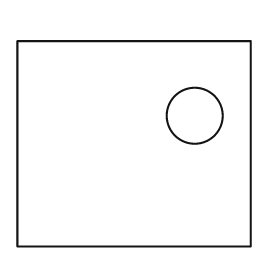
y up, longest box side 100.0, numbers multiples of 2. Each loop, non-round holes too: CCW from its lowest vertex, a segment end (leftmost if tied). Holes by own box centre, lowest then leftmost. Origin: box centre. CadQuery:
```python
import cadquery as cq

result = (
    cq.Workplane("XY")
    .moveTo(-50.0, -44.0)
    .lineTo(50.0, -44.0)
    .lineTo(50.0, 44.0)
    .lineTo(-50.0, 44.0)
    .close()
    .moveTo(26.0, 12.0)
    .circle(12.0)
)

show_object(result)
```